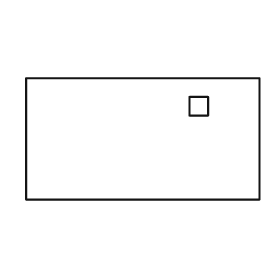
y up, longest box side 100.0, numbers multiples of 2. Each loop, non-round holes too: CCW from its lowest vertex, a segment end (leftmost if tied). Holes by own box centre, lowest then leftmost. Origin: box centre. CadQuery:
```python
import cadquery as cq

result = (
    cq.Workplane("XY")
    .moveTo(-50.0, -26.0)
    .lineTo(50.0, -26.0)
    .lineTo(50.0, 26.0)
    .lineTo(-50.0, 26.0)
    .close()
    .moveTo(20.0, 10.0)
    .lineTo(28.0, 10.0)
    .lineTo(28.0, 18.0)
    .lineTo(20.0, 18.0)
    .close()
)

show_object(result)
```